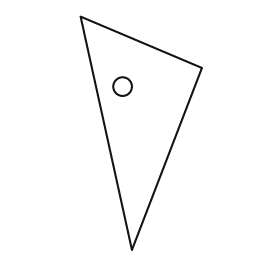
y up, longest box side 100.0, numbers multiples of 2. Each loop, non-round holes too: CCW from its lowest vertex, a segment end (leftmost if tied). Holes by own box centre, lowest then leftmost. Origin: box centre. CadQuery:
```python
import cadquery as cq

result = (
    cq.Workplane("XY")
    .moveTo(-4.0, -50.0)
    .lineTo(26.0, 28.0)
    .lineTo(-26.0, 50.0)
    .close()
    .moveTo(-8.0, 20.0)
    .circle(4.0)
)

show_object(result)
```